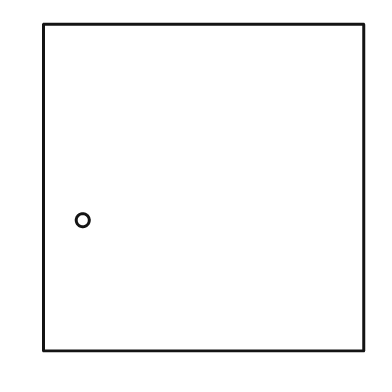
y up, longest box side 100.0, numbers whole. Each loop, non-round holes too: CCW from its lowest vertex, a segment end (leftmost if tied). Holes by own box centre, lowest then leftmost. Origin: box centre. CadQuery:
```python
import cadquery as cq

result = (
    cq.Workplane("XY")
    .moveTo(-49.0, -50.0)
    .lineTo(49.0, -50.0)
    .lineTo(49.0, 50.0)
    .lineTo(-49.0, 50.0)
    .close()
    .moveTo(-37.0, -10.0)
    .circle(2.0)
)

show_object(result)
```